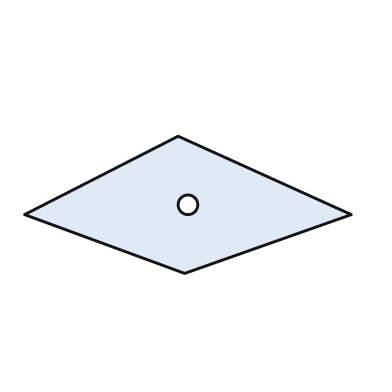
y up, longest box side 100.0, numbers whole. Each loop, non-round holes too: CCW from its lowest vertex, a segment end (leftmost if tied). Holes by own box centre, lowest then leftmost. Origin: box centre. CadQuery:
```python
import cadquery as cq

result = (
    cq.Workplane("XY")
    .moveTo(-1.0, -21.0)
    .lineTo(50.0, -3.0)
    .lineTo(-3.0, 21.0)
    .lineTo(-50.0, -3.0)
    .close()
    .moveTo(0.0, 0.0)
    .circle(3.0)
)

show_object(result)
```